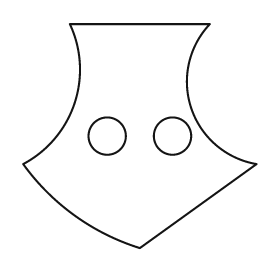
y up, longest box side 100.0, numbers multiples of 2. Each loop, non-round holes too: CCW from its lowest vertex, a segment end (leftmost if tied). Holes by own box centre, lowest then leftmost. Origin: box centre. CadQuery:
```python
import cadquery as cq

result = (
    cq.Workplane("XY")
    .moveTo(0.0, -48.0)
    .lineTo(50.0, -12.0)
    .threePointArc((22.0, 12.0), (30.0, 48.0))
    .lineTo(-30.0, 48.0)
    .threePointArc((-28.0, 14.0), (-50.0, -12.0))
    .threePointArc((-28.0, -34.0), (0.0, -48.0))
    .close()
    .moveTo(-14.0, 0.0)
    .circle(8.0)
    .moveTo(14.0, 0.0)
    .circle(8.0)
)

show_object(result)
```